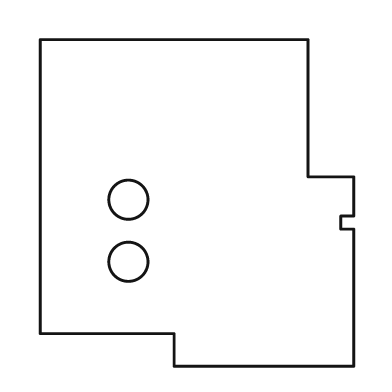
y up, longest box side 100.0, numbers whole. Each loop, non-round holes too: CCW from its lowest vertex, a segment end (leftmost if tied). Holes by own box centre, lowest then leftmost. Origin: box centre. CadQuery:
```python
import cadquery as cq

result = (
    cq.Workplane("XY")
    .moveTo(-7.0, -50.0)
    .lineTo(48.0, -50.0)
    .lineTo(48.0, -8.0)
    .lineTo(44.0, -8.0)
    .lineTo(44.0, -4.0)
    .lineTo(48.0, -4.0)
    .lineTo(48.0, 8.0)
    .lineTo(34.0, 8.0)
    .lineTo(34.0, 50.0)
    .lineTo(-48.0, 50.0)
    .lineTo(-48.0, -40.0)
    .lineTo(-7.0, -40.0)
    .close()
    .moveTo(-21.0, -18.0)
    .circle(6.0)
    .moveTo(-21.0, 1.0)
    .circle(6.0)
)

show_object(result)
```